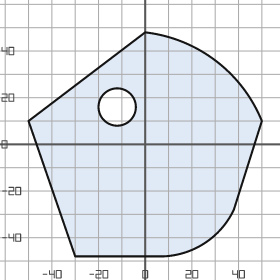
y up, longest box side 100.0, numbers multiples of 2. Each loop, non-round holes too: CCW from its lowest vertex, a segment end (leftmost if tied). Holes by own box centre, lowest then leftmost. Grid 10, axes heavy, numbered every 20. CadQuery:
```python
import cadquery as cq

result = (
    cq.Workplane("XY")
    .moveTo(-30.0, -48.0)
    .lineTo(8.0, -48.0)
    .threePointArc((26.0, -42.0), (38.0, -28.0))
    .lineTo(50.0, 10.0)
    .threePointArc((30.0, 36.0), (0.0, 48.0))
    .lineTo(-50.0, 10.0)
    .close()
    .moveTo(-12.0, 16.0)
    .circle(8.0)
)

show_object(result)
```